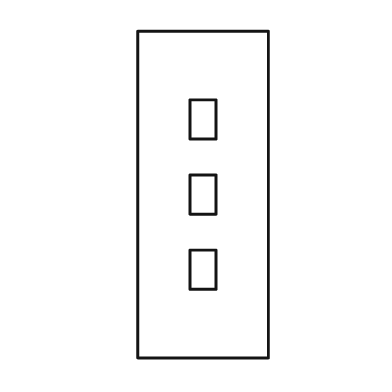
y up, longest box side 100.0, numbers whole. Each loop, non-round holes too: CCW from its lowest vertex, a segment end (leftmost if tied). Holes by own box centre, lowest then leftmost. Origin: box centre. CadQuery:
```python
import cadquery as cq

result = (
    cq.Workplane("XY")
    .moveTo(-20.0, -50.0)
    .lineTo(20.0, -50.0)
    .lineTo(20.0, 50.0)
    .lineTo(-20.0, 50.0)
    .close()
    .moveTo(-4.0, -29.0)
    .lineTo(4.0, -29.0)
    .lineTo(4.0, -17.0)
    .lineTo(-4.0, -17.0)
    .close()
    .moveTo(-4.0, -6.0)
    .lineTo(4.0, -6.0)
    .lineTo(4.0, 6.0)
    .lineTo(-4.0, 6.0)
    .close()
    .moveTo(-4.0, 17.0)
    .lineTo(4.0, 17.0)
    .lineTo(4.0, 29.0)
    .lineTo(-4.0, 29.0)
    .close()
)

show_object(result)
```